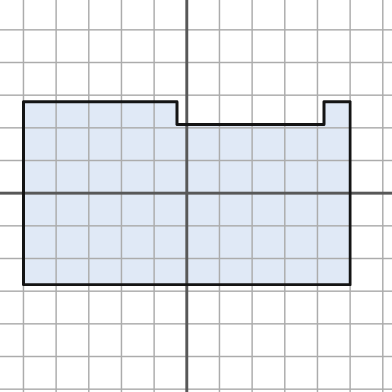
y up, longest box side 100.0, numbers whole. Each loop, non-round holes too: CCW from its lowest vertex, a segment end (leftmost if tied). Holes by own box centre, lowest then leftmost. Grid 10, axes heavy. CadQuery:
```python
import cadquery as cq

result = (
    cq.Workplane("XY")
    .moveTo(-50.0, -28.0)
    .lineTo(50.0, -28.0)
    .lineTo(50.0, 28.0)
    .lineTo(42.0, 28.0)
    .lineTo(42.0, 21.0)
    .lineTo(-3.0, 21.0)
    .lineTo(-3.0, 28.0)
    .lineTo(-50.0, 28.0)
    .close()
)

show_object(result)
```